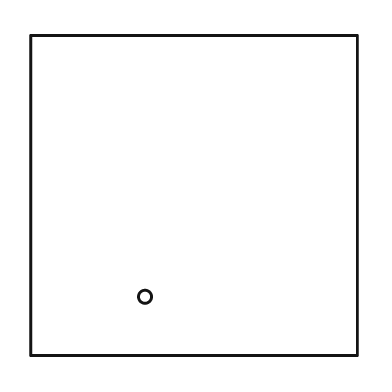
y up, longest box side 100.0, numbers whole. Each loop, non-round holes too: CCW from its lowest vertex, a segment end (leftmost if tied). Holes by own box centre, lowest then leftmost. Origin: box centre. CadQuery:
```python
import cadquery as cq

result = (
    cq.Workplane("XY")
    .moveTo(-50.0, -49.0)
    .lineTo(50.0, -49.0)
    .lineTo(50.0, 49.0)
    .lineTo(-50.0, 49.0)
    .close()
    .moveTo(-15.0, -31.0)
    .circle(2.0)
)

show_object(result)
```